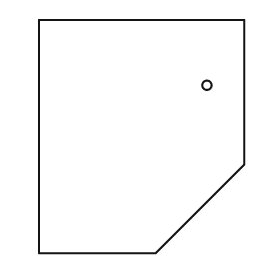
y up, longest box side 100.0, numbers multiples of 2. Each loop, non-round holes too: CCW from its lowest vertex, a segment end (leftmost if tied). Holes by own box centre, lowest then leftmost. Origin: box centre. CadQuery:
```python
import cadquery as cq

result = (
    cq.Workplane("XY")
    .moveTo(-44.0, -50.0)
    .lineTo(6.0, -50.0)
    .lineTo(44.0, -12.0)
    .lineTo(44.0, 50.0)
    .lineTo(-44.0, 50.0)
    .close()
    .moveTo(28.0, 22.0)
    .circle(2.0)
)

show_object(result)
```